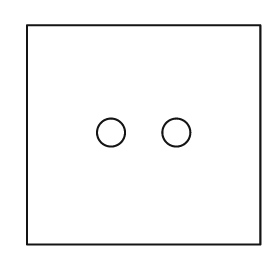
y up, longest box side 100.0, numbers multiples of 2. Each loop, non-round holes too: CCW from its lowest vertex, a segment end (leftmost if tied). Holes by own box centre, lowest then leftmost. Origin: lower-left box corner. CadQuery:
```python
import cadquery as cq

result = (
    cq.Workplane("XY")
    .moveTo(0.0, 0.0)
    .lineTo(100.0, 0.0)
    .lineTo(100.0, 94.0)
    .lineTo(0.0, 94.0)
    .close()
    .moveTo(36.0, 48.0)
    .circle(6.0)
    .moveTo(64.0, 48.0)
    .circle(6.0)
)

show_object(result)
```